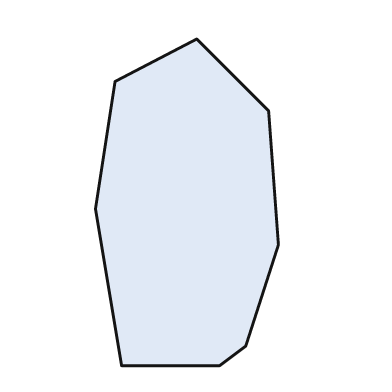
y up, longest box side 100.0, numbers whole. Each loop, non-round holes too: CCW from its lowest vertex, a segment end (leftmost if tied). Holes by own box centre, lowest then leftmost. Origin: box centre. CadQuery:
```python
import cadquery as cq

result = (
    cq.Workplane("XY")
    .moveTo(-20.0, -50.0)
    .lineTo(10.0, -50.0)
    .lineTo(18.0, -44.0)
    .lineTo(28.0, -13.0)
    .lineTo(25.0, 28.0)
    .lineTo(3.0, 50.0)
    .lineTo(-22.0, 37.0)
    .lineTo(-28.0, -2.0)
    .close()
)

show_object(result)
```